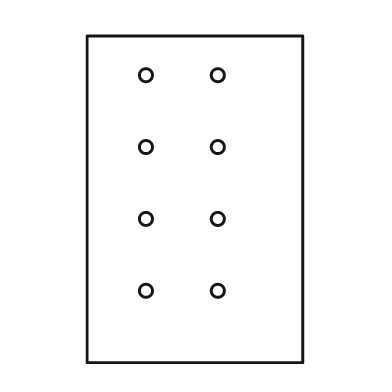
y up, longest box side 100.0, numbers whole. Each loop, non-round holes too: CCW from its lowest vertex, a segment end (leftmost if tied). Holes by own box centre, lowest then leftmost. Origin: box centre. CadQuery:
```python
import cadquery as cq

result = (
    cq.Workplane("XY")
    .moveTo(-33.0, -50.0)
    .lineTo(33.0, -50.0)
    .lineTo(33.0, 50.0)
    .lineTo(-33.0, 50.0)
    .close()
    .moveTo(-15.0, -28.0)
    .circle(2.0)
    .moveTo(7.0, -28.0)
    .circle(2.0)
    .moveTo(-15.0, -6.0)
    .circle(2.0)
    .moveTo(7.0, -6.0)
    .circle(2.0)
    .moveTo(-15.0, 16.0)
    .circle(2.0)
    .moveTo(7.0, 16.0)
    .circle(2.0)
    .moveTo(-15.0, 38.0)
    .circle(2.0)
    .moveTo(7.0, 38.0)
    .circle(2.0)
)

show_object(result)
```